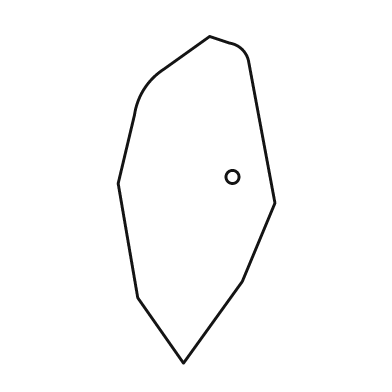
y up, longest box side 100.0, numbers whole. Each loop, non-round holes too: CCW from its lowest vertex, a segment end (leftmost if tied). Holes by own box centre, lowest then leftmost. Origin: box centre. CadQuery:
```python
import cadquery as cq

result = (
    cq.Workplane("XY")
    .moveTo(-4.0, -50.0)
    .lineTo(14.0, -25.0)
    .lineTo(24.0, -1.0)
    .lineTo(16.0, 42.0)
    .threePointArc((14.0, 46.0), (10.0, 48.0))
    .lineTo(4.0, 50.0)
    .lineTo(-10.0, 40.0)
    .threePointArc((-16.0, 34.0), (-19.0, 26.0))
    .lineTo(-24.0, 5.0)
    .lineTo(-18.0, -30.0)
    .close()
    .moveTo(11.0, 7.0)
    .circle(2.0)
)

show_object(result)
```